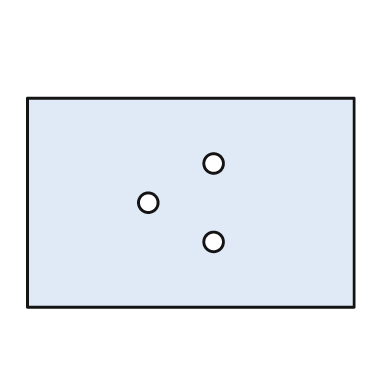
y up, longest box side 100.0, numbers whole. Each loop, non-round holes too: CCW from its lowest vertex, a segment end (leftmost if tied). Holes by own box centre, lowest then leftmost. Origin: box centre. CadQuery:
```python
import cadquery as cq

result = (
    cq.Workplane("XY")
    .moveTo(-50.0, -32.0)
    .lineTo(50.0, -32.0)
    .lineTo(50.0, 32.0)
    .lineTo(-50.0, 32.0)
    .close()
    .moveTo(7.0, -12.0)
    .circle(3.0)
    .moveTo(-13.0, 0.0)
    .circle(3.0)
    .moveTo(7.0, 12.0)
    .circle(3.0)
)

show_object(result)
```